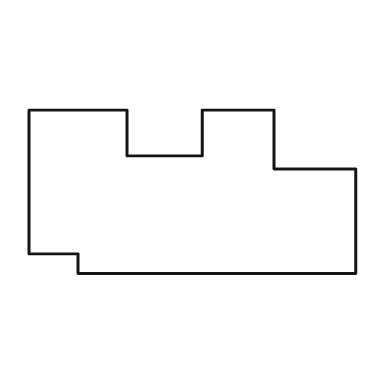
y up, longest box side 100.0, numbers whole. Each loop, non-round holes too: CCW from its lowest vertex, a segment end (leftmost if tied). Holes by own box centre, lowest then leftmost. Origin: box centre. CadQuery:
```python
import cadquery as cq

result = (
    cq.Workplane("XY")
    .moveTo(-35.0, -25.0)
    .lineTo(50.0, -25.0)
    .lineTo(50.0, 7.0)
    .lineTo(25.0, 7.0)
    .lineTo(25.0, 25.0)
    .lineTo(3.0, 25.0)
    .lineTo(3.0, 11.0)
    .lineTo(-20.0, 11.0)
    .lineTo(-20.0, 25.0)
    .lineTo(-50.0, 25.0)
    .lineTo(-50.0, -19.0)
    .lineTo(-35.0, -19.0)
    .close()
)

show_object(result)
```